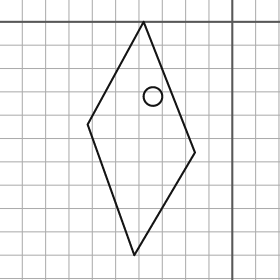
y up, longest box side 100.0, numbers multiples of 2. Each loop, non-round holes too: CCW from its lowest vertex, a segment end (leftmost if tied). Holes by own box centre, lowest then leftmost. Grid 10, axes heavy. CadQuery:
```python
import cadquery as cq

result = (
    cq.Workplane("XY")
    .moveTo(-42.0, -100.0)
    .lineTo(-16.0, -56.0)
    .lineTo(-38.0, 0.0)
    .lineTo(-62.0, -44.0)
    .close()
    .moveTo(-34.0, -32.0)
    .circle(4.0)
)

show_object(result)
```